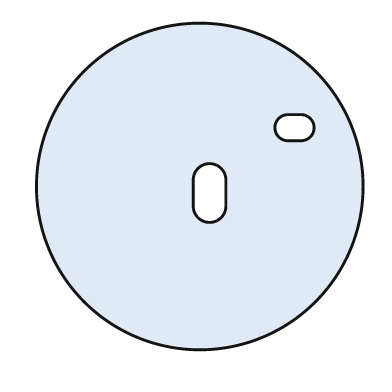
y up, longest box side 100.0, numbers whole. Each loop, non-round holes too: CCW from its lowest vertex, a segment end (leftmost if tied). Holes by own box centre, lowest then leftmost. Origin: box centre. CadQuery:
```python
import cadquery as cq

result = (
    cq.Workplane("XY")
    .moveTo(0.0, 0.0)
    .circle(50.0)
    .moveTo(-2.0, -6.0)
    .threePointArc((3.0, -11.0), (8.0, -6.0))
    .lineTo(8.0, 2.0)
    .threePointArc((3.0, 7.0), (-2.0, 2.0))
    .close()
    .moveTo(27.0, 14.0)
    .lineTo(31.0, 14.0)
    .threePointArc((35.0, 18.0), (31.0, 22.0))
    .lineTo(27.0, 22.0)
    .threePointArc((23.0, 18.0), (27.0, 14.0))
    .close()
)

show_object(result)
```